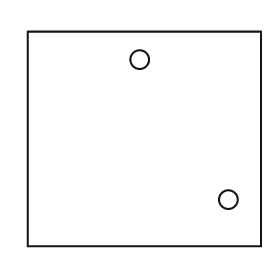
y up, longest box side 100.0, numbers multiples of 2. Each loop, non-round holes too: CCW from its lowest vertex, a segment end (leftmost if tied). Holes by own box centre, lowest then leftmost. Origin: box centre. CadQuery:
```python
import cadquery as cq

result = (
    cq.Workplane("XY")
    .moveTo(-50.0, -46.0)
    .lineTo(50.0, -46.0)
    .lineTo(50.0, 46.0)
    .lineTo(-50.0, 46.0)
    .close()
    .moveTo(36.0, -26.0)
    .circle(4.0)
    .moveTo(-2.0, 34.0)
    .circle(4.0)
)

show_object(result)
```